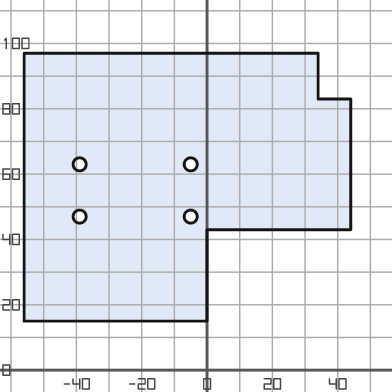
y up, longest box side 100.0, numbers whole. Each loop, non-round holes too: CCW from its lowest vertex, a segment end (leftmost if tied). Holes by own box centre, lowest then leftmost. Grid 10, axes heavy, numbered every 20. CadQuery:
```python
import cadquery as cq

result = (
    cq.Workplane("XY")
    .moveTo(-56.0, 15.0)
    .lineTo(0.0, 15.0)
    .lineTo(0.0, 43.0)
    .lineTo(44.0, 43.0)
    .lineTo(44.0, 83.0)
    .lineTo(34.0, 83.0)
    .lineTo(34.0, 97.0)
    .lineTo(-56.0, 97.0)
    .close()
    .moveTo(-39.0, 47.0)
    .circle(2.0)
    .moveTo(-5.0, 47.0)
    .circle(2.0)
    .moveTo(-39.0, 63.0)
    .circle(2.0)
    .moveTo(-5.0, 63.0)
    .circle(2.0)
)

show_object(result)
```